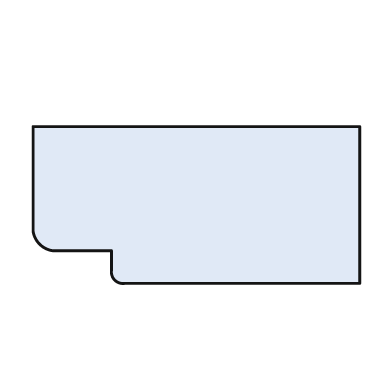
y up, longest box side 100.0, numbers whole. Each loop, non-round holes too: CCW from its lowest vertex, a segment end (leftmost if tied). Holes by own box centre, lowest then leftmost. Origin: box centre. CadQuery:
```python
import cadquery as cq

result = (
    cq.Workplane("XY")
    .moveTo(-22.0, -24.0)
    .lineTo(50.0, -24.0)
    .lineTo(50.0, 24.0)
    .lineTo(-50.0, 24.0)
    .lineTo(-50.0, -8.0)
    .threePointArc((-48.0, -12.0), (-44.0, -14.0))
    .lineTo(-26.0, -14.0)
    .lineTo(-26.0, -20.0)
    .threePointArc((-25.0, -23.0), (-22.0, -24.0))
    .close()
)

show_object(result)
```